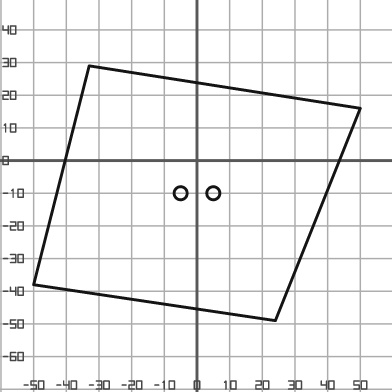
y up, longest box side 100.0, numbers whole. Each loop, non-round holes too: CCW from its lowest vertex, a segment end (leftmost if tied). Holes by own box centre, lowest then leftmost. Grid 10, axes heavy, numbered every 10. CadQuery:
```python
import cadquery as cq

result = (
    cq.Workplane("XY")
    .moveTo(24.0, -49.0)
    .lineTo(50.0, 16.0)
    .lineTo(-33.0, 29.0)
    .lineTo(-50.0, -38.0)
    .close()
    .moveTo(-5.0, -10.0)
    .circle(2.0)
    .moveTo(5.0, -10.0)
    .circle(2.0)
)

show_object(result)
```